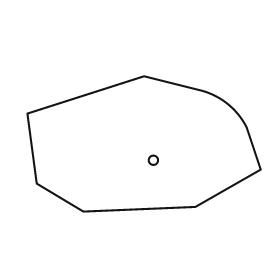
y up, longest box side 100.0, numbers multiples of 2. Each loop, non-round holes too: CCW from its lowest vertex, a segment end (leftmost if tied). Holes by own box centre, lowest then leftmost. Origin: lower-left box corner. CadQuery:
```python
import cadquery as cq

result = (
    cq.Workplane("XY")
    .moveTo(24.0, 0.0)
    .lineTo(72.0, 2.0)
    .lineTo(100.0, 18.0)
    .lineTo(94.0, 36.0)
    .threePointArc((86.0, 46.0), (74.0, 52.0))
    .lineTo(50.0, 58.0)
    .lineTo(0.0, 42.0)
    .lineTo(4.0, 12.0)
    .close()
    .moveTo(54.0, 22.0)
    .circle(2.0)
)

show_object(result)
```